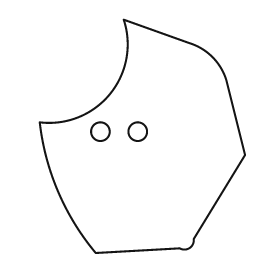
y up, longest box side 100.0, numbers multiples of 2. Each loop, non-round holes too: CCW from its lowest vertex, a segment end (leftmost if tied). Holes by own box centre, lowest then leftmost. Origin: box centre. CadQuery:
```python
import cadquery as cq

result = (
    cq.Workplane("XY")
    .moveTo(-20.0, -50.0)
    .lineTo(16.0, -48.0)
    .threePointArc((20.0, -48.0), (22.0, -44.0))
    .lineTo(44.0, -8.0)
    .lineTo(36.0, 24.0)
    .threePointArc((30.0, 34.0), (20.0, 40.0))
    .lineTo(-8.0, 50.0)
    .threePointArc((-14.0, 18.0), (-44.0, 6.0))
    .threePointArc((-36.0, -24.0), (-20.0, -50.0))
    .close()
    .moveTo(-18.0, 2.0)
    .circle(4.0)
    .moveTo(-2.0, 2.0)
    .circle(4.0)
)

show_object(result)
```